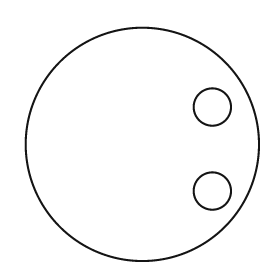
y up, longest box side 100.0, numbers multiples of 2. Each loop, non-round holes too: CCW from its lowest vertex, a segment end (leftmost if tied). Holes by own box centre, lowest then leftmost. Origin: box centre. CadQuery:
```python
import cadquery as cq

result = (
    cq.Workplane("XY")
    .moveTo(0.0, 0.0)
    .circle(50.0)
    .moveTo(30.0, -20.0)
    .circle(8.0)
    .moveTo(30.0, 16.0)
    .circle(8.0)
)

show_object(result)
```